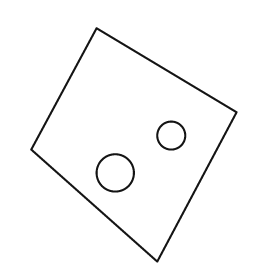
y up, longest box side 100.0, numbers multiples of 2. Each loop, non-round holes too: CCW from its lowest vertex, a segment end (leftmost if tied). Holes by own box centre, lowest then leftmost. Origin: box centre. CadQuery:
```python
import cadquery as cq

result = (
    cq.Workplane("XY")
    .moveTo(10.0, -50.0)
    .lineTo(44.0, 14.0)
    .lineTo(-16.0, 50.0)
    .lineTo(-44.0, -2.0)
    .close()
    .moveTo(-8.0, -12.0)
    .circle(8.0)
    .moveTo(16.0, 4.0)
    .circle(6.0)
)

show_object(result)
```